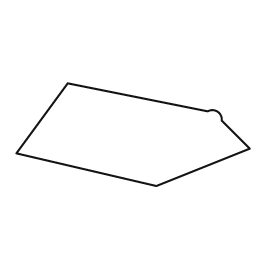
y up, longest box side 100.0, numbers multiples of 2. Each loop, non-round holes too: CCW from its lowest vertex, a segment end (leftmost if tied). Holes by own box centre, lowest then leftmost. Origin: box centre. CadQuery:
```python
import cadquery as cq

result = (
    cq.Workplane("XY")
    .moveTo(10.0, -22.0)
    .lineTo(50.0, -6.0)
    .lineTo(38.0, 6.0)
    .threePointArc((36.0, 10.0), (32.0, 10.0))
    .lineTo(-28.0, 22.0)
    .lineTo(-50.0, -8.0)
    .close()
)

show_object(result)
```